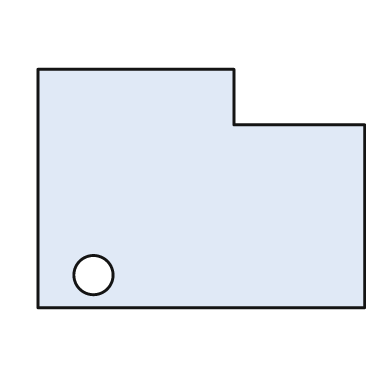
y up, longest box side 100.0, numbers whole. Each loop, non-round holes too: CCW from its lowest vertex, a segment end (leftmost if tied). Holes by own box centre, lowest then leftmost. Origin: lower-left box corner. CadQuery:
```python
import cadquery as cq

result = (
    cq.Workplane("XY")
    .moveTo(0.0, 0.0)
    .lineTo(100.0, 0.0)
    .lineTo(100.0, 56.0)
    .lineTo(60.0, 56.0)
    .lineTo(60.0, 73.0)
    .lineTo(0.0, 73.0)
    .close()
    .moveTo(17.0, 10.0)
    .circle(6.0)
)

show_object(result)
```